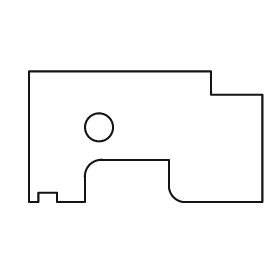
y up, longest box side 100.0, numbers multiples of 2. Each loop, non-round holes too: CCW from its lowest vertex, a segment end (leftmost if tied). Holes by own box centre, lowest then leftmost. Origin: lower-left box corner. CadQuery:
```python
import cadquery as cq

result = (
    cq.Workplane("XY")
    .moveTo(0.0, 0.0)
    .lineTo(4.0, 0.0)
    .lineTo(4.0, 4.0)
    .lineTo(12.0, 4.0)
    .lineTo(12.0, 0.0)
    .lineTo(24.0, 0.0)
    .lineTo(24.0, 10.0)
    .threePointArc((26.0, 16.0), (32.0, 18.0))
    .lineTo(60.0, 18.0)
    .lineTo(60.0, 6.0)
    .threePointArc((62.0, 2.0), (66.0, 0.0))
    .lineTo(100.0, 0.0)
    .lineTo(100.0, 46.0)
    .lineTo(78.0, 46.0)
    .lineTo(78.0, 56.0)
    .lineTo(0.0, 56.0)
    .close()
    .moveTo(30.0, 32.0)
    .circle(6.0)
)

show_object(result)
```